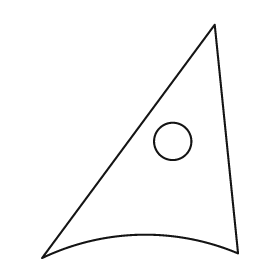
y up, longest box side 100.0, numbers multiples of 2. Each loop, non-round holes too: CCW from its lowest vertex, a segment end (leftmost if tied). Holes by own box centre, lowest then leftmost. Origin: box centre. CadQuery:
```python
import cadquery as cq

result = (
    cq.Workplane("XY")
    .moveTo(-42.0, -50.0)
    .threePointArc((0.0, -40.0), (42.0, -48.0))
    .lineTo(32.0, 50.0)
    .close()
    .moveTo(14.0, 0.0)
    .circle(8.0)
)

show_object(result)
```